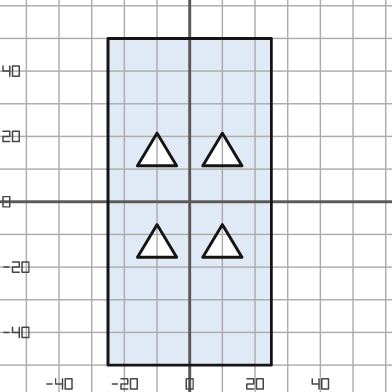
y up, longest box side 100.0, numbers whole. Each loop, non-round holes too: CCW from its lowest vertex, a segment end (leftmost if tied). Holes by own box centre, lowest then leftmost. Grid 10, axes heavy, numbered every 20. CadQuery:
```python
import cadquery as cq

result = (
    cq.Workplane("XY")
    .moveTo(-25.0, -50.0)
    .lineTo(25.0, -50.0)
    .lineTo(25.0, 50.0)
    .lineTo(-25.0, 50.0)
    .close()
    .moveTo(-16.0, -17.0)
    .lineTo(-4.0, -17.0)
    .lineTo(-10.0, -7.0)
    .close()
    .moveTo(4.0, -17.0)
    .lineTo(16.0, -17.0)
    .lineTo(10.0, -7.0)
    .close()
    .moveTo(-16.0, 11.0)
    .lineTo(-4.0, 11.0)
    .lineTo(-10.0, 21.0)
    .close()
    .moveTo(4.0, 11.0)
    .lineTo(16.0, 11.0)
    .lineTo(10.0, 21.0)
    .close()
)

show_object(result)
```